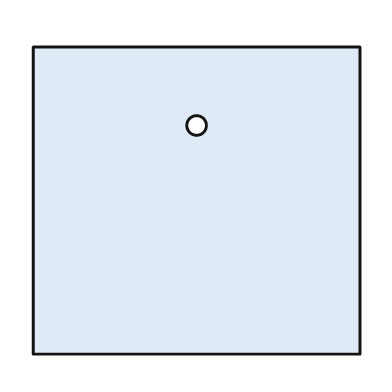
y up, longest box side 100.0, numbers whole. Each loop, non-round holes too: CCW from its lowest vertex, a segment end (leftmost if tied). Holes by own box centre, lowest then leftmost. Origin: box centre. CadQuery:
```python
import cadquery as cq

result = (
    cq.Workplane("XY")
    .moveTo(-50.0, -47.0)
    .lineTo(50.0, -47.0)
    .lineTo(50.0, 47.0)
    .lineTo(-50.0, 47.0)
    .close()
    .moveTo(0.0, 23.0)
    .circle(3.0)
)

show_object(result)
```